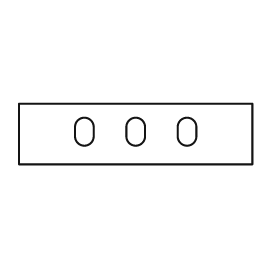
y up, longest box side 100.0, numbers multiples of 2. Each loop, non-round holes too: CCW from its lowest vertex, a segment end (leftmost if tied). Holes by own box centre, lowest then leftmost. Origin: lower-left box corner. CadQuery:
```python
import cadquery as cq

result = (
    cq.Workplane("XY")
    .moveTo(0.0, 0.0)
    .lineTo(100.0, 0.0)
    .lineTo(100.0, 26.0)
    .lineTo(0.0, 26.0)
    .close()
    .moveTo(24.0, 12.0)
    .threePointArc((28.0, 8.0), (32.0, 12.0))
    .lineTo(32.0, 16.0)
    .threePointArc((28.0, 20.0), (24.0, 16.0))
    .close()
    .moveTo(46.0, 12.0)
    .threePointArc((50.0, 8.0), (54.0, 12.0))
    .lineTo(54.0, 16.0)
    .threePointArc((50.0, 20.0), (46.0, 16.0))
    .close()
    .moveTo(68.0, 12.0)
    .threePointArc((72.0, 8.0), (76.0, 12.0))
    .lineTo(76.0, 16.0)
    .threePointArc((72.0, 20.0), (68.0, 16.0))
    .close()
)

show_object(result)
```